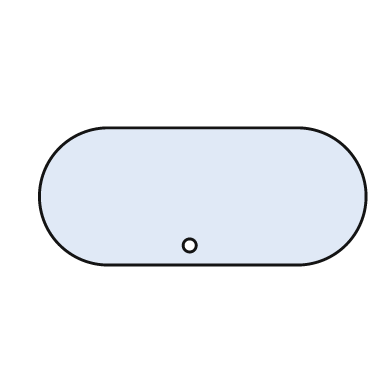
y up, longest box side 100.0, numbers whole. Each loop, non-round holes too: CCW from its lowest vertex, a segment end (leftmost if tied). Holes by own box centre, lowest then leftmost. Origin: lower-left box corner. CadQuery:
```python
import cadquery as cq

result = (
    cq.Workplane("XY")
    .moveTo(21.0, 0.0)
    .lineTo(79.0, 0.0)
    .threePointArc((100.0, 21.0), (79.0, 42.0))
    .lineTo(21.0, 42.0)
    .threePointArc((0.0, 21.0), (21.0, 0.0))
    .close()
    .moveTo(46.0, 6.0)
    .circle(2.0)
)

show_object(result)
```